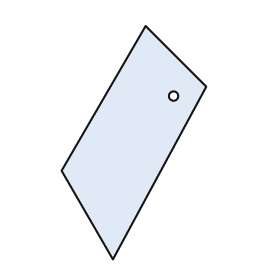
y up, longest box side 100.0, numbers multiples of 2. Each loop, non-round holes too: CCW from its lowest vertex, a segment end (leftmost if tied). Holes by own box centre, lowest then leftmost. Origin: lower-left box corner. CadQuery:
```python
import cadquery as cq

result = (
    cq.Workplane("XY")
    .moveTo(22.0, 0.0)
    .lineTo(62.0, 74.0)
    .lineTo(36.0, 100.0)
    .lineTo(0.0, 38.0)
    .close()
    .moveTo(48.0, 70.0)
    .circle(2.0)
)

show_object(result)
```